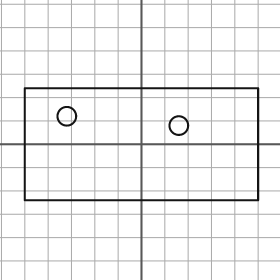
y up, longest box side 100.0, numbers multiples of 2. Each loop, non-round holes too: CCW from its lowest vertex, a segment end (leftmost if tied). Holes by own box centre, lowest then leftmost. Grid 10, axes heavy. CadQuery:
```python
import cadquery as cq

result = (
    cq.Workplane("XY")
    .moveTo(-50.0, -24.0)
    .lineTo(50.0, -24.0)
    .lineTo(50.0, 24.0)
    .lineTo(-50.0, 24.0)
    .close()
    .moveTo(16.0, 8.0)
    .circle(4.0)
    .moveTo(-32.0, 12.0)
    .circle(4.0)
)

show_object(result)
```